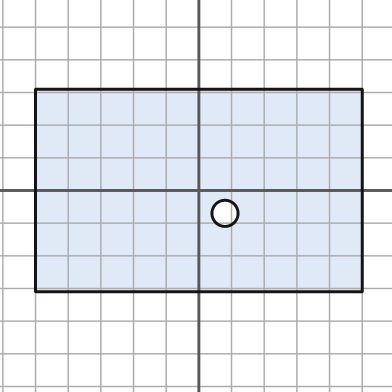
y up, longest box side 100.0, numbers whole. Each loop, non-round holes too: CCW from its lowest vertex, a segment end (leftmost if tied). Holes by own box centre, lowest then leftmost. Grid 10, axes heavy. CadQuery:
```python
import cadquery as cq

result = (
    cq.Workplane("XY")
    .moveTo(-50.0, -31.0)
    .lineTo(50.0, -31.0)
    .lineTo(50.0, 31.0)
    .lineTo(-50.0, 31.0)
    .close()
    .moveTo(8.0, -7.0)
    .circle(4.0)
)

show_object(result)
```